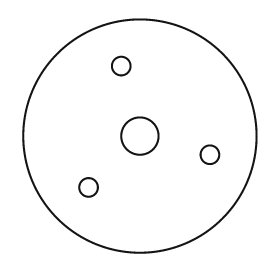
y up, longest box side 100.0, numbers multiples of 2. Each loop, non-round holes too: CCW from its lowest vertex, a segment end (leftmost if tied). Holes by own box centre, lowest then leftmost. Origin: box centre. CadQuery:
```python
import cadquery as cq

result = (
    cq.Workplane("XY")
    .moveTo(0.0, 0.0)
    .circle(50.0)
    .moveTo(-22.0, -22.0)
    .circle(4.0)
    .moveTo(30.0, -8.0)
    .circle(4.0)
    .moveTo(0.0, 0.0)
    .circle(8.0)
    .moveTo(-8.0, 30.0)
    .circle(4.0)
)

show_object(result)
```